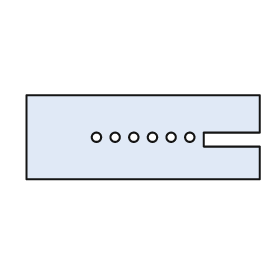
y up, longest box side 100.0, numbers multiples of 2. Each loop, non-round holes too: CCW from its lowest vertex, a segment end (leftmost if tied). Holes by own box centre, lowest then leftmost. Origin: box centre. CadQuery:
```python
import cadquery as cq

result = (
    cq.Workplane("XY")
    .moveTo(-50.0, -18.0)
    .lineTo(50.0, -18.0)
    .lineTo(50.0, -4.0)
    .lineTo(26.0, -4.0)
    .lineTo(26.0, 2.0)
    .lineTo(50.0, 2.0)
    .lineTo(50.0, 18.0)
    .lineTo(-50.0, 18.0)
    .close()
    .moveTo(-20.0, 0.0)
    .circle(2.0)
    .moveTo(-12.0, 0.0)
    .circle(2.0)
    .moveTo(-4.0, 0.0)
    .circle(2.0)
    .moveTo(4.0, 0.0)
    .circle(2.0)
    .moveTo(12.0, 0.0)
    .circle(2.0)
    .moveTo(20.0, 0.0)
    .circle(2.0)
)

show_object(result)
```